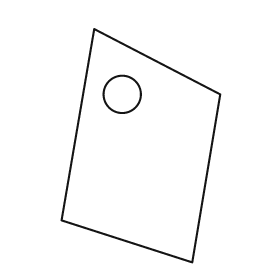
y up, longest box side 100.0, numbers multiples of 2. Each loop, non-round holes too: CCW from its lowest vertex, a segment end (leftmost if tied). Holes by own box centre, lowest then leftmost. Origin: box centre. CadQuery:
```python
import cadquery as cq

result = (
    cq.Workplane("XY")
    .moveTo(22.0, -50.0)
    .lineTo(34.0, 22.0)
    .lineTo(-20.0, 50.0)
    .lineTo(-34.0, -32.0)
    .close()
    .moveTo(-8.0, 22.0)
    .circle(8.0)
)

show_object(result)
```